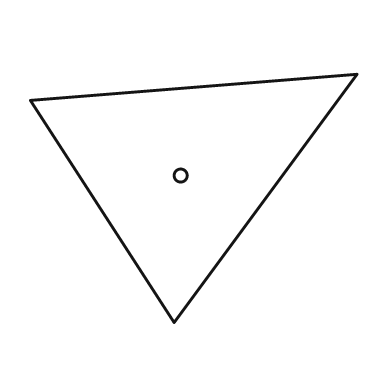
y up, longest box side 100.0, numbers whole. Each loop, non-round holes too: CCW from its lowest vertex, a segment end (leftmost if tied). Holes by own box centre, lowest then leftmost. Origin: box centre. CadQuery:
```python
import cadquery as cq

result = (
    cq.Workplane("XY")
    .moveTo(-6.0, -38.0)
    .lineTo(50.0, 38.0)
    .lineTo(-50.0, 30.0)
    .close()
    .moveTo(-4.0, 7.0)
    .circle(2.0)
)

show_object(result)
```